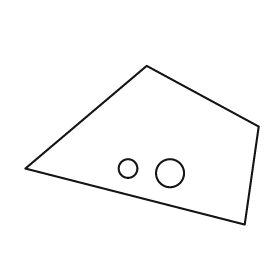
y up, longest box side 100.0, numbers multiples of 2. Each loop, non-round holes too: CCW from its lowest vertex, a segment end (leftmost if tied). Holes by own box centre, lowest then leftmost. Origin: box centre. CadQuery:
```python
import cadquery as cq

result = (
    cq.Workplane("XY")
    .moveTo(44.0, -34.0)
    .lineTo(50.0, 8.0)
    .lineTo(2.0, 34.0)
    .lineTo(-50.0, -10.0)
    .close()
    .moveTo(12.0, -12.0)
    .circle(6.0)
    .moveTo(-6.0, -10.0)
    .circle(4.0)
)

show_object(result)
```